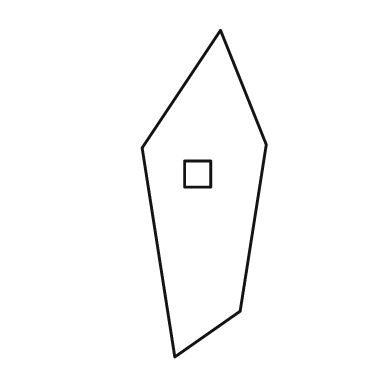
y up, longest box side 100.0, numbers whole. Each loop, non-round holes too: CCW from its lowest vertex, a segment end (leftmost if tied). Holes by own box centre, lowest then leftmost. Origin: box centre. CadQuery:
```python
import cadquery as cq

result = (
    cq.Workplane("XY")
    .moveTo(-9.0, -50.0)
    .lineTo(11.0, -36.0)
    .lineTo(19.0, 15.0)
    .lineTo(5.0, 50.0)
    .lineTo(-19.0, 14.0)
    .close()
    .moveTo(-6.0, 2.0)
    .lineTo(2.0, 2.0)
    .lineTo(2.0, 10.0)
    .lineTo(-6.0, 10.0)
    .close()
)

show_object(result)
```